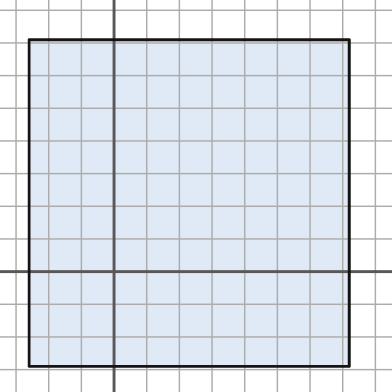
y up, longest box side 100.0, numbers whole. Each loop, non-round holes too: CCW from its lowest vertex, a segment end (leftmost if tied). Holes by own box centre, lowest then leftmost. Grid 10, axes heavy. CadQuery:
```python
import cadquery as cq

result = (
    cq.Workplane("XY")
    .moveTo(-26.0, -29.0)
    .lineTo(72.0, -29.0)
    .lineTo(72.0, 71.0)
    .lineTo(-26.0, 71.0)
    .close()
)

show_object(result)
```